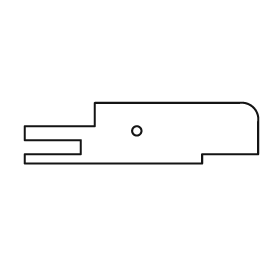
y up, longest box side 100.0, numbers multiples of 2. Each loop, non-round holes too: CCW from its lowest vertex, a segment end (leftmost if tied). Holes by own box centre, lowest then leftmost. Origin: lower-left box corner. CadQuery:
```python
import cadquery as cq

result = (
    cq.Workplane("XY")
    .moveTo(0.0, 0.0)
    .lineTo(76.0, 0.0)
    .lineTo(76.0, 4.0)
    .lineTo(100.0, 4.0)
    .lineTo(100.0, 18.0)
    .threePointArc((98.0, 24.0), (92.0, 26.0))
    .lineTo(30.0, 26.0)
    .lineTo(30.0, 16.0)
    .lineTo(0.0, 16.0)
    .lineTo(0.0, 10.0)
    .lineTo(24.0, 10.0)
    .lineTo(24.0, 4.0)
    .lineTo(0.0, 4.0)
    .close()
    .moveTo(48.0, 14.0)
    .circle(2.0)
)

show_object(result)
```